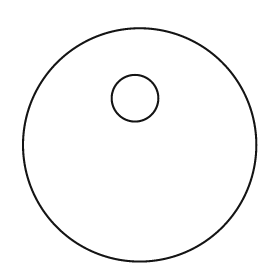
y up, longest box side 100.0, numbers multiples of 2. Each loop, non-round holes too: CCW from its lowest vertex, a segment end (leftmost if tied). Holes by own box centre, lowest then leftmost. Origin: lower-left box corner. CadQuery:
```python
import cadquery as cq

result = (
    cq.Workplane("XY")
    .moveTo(50.0, 50.0)
    .circle(50.0)
    .moveTo(48.0, 70.0)
    .circle(10.0)
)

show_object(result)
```